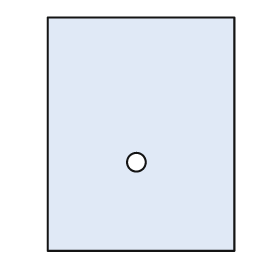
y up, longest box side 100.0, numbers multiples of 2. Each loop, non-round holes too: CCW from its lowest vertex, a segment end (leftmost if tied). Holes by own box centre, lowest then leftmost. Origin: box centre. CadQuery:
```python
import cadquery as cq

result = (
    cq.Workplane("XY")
    .moveTo(-40.0, -50.0)
    .lineTo(40.0, -50.0)
    .lineTo(40.0, 50.0)
    .lineTo(-40.0, 50.0)
    .close()
    .moveTo(-2.0, -12.0)
    .circle(4.0)
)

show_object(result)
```